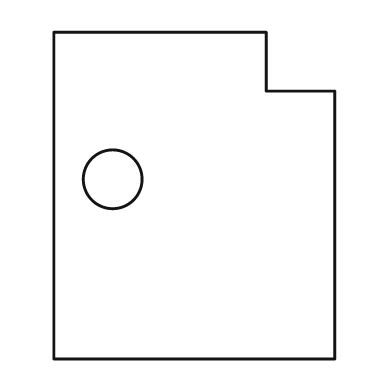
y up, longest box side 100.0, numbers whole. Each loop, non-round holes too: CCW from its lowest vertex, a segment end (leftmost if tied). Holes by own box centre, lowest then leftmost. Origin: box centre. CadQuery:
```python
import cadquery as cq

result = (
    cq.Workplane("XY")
    .moveTo(-43.0, -50.0)
    .lineTo(43.0, -50.0)
    .lineTo(43.0, 32.0)
    .lineTo(22.0, 32.0)
    .lineTo(22.0, 50.0)
    .lineTo(-43.0, 50.0)
    .close()
    .moveTo(-25.0, 5.0)
    .circle(9.0)
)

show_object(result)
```